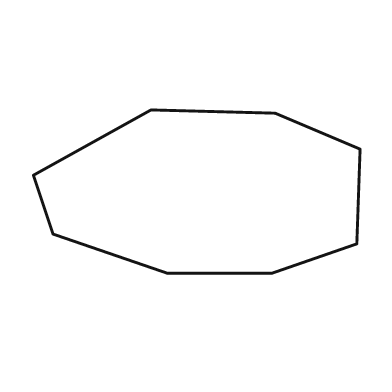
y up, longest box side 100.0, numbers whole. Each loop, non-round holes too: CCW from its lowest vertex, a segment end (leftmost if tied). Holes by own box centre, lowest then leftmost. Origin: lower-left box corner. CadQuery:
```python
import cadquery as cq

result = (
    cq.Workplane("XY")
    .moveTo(41.0, 0.0)
    .lineTo(73.0, 0.0)
    .lineTo(99.0, 9.0)
    .lineTo(100.0, 38.0)
    .lineTo(74.0, 49.0)
    .lineTo(36.0, 50.0)
    .lineTo(0.0, 30.0)
    .lineTo(6.0, 12.0)
    .close()
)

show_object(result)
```